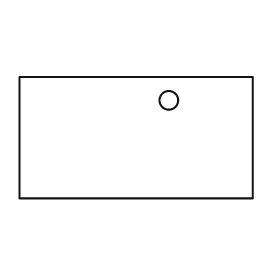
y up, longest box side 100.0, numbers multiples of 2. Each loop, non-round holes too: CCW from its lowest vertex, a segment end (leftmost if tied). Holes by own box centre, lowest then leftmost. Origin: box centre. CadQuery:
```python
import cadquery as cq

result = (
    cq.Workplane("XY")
    .moveTo(-50.0, -26.0)
    .lineTo(50.0, -26.0)
    .lineTo(50.0, 26.0)
    .lineTo(-50.0, 26.0)
    .close()
    .moveTo(14.0, 16.0)
    .circle(4.0)
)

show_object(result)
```